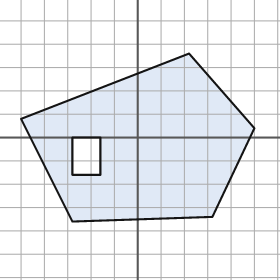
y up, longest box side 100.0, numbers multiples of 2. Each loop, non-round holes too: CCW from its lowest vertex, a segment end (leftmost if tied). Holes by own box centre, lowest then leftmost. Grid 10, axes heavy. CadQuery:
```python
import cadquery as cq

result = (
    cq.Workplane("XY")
    .moveTo(-28.0, -36.0)
    .lineTo(32.0, -34.0)
    .lineTo(50.0, 4.0)
    .lineTo(22.0, 36.0)
    .lineTo(-50.0, 8.0)
    .close()
    .moveTo(-28.0, -16.0)
    .lineTo(-16.0, -16.0)
    .lineTo(-16.0, 0.0)
    .lineTo(-28.0, 0.0)
    .close()
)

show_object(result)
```